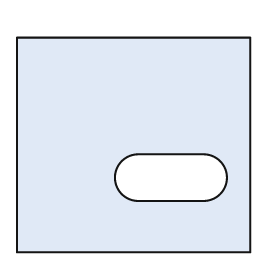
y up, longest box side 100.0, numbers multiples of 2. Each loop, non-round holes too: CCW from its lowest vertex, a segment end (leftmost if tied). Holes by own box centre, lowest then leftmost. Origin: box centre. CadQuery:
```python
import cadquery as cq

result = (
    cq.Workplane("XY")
    .moveTo(-50.0, -46.0)
    .lineTo(50.0, -46.0)
    .lineTo(50.0, 46.0)
    .lineTo(-50.0, 46.0)
    .close()
    .moveTo(2.0, -24.0)
    .lineTo(30.0, -24.0)
    .threePointArc((40.0, -14.0), (30.0, -4.0))
    .lineTo(2.0, -4.0)
    .threePointArc((-8.0, -14.0), (2.0, -24.0))
    .close()
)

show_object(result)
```